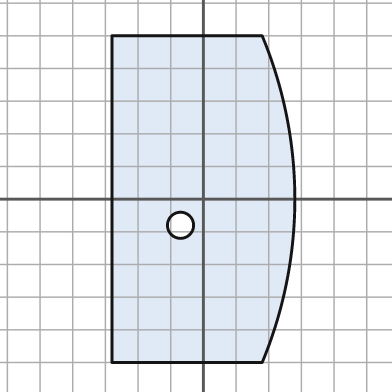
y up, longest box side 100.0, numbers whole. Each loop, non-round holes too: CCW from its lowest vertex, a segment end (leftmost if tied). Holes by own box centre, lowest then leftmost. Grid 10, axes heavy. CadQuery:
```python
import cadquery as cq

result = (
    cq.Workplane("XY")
    .moveTo(-28.0, -50.0)
    .lineTo(18.0, -50.0)
    .threePointArc((28.0, 0.0), (18.0, 50.0))
    .lineTo(-28.0, 50.0)
    .close()
    .moveTo(-7.0, -8.0)
    .circle(4.0)
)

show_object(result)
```